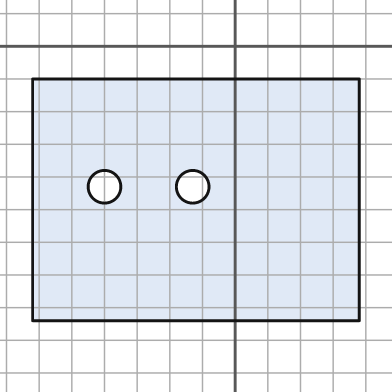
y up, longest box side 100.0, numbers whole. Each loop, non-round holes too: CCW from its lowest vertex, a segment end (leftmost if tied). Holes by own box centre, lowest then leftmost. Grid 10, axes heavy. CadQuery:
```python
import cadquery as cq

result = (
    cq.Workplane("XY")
    .moveTo(-62.0, -84.0)
    .lineTo(38.0, -84.0)
    .lineTo(38.0, -10.0)
    .lineTo(-62.0, -10.0)
    .close()
    .moveTo(-40.0, -43.0)
    .circle(5.0)
    .moveTo(-13.0, -43.0)
    .circle(5.0)
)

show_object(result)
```